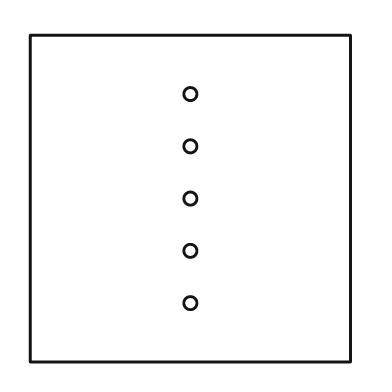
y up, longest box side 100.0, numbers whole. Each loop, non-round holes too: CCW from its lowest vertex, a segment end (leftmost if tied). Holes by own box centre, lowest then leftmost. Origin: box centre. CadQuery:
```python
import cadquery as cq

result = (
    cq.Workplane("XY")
    .moveTo(-49.0, -50.0)
    .lineTo(49.0, -50.0)
    .lineTo(49.0, 50.0)
    .lineTo(-49.0, 50.0)
    .close()
    .moveTo(0.0, -32.0)
    .circle(2.0)
    .moveTo(0.0, -16.0)
    .circle(2.0)
    .moveTo(0.0, 0.0)
    .circle(2.0)
    .moveTo(0.0, 16.0)
    .circle(2.0)
    .moveTo(0.0, 32.0)
    .circle(2.0)
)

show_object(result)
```